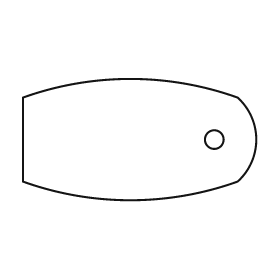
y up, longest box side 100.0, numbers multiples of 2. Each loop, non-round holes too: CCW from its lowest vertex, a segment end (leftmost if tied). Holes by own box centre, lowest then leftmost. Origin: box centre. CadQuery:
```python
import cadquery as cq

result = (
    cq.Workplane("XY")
    .moveTo(-50.0, -18.0)
    .threePointArc((-4.0, -26.0), (42.0, -18.0))
    .threePointArc((50.0, 0.0), (42.0, 18.0))
    .threePointArc((-4.0, 26.0), (-50.0, 18.0))
    .close()
    .moveTo(32.0, 0.0)
    .circle(4.0)
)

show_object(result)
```